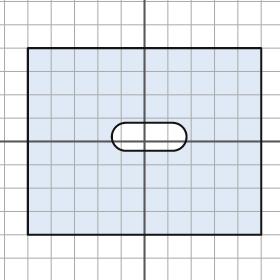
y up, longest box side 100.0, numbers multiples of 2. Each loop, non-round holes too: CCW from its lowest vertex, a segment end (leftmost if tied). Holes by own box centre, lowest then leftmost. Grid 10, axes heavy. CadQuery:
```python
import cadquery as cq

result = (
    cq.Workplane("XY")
    .moveTo(-50.0, -40.0)
    .lineTo(50.0, -40.0)
    .lineTo(50.0, 40.0)
    .lineTo(-50.0, 40.0)
    .close()
    .moveTo(-8.0, -4.0)
    .lineTo(12.0, -4.0)
    .threePointArc((18.0, 2.0), (12.0, 8.0))
    .lineTo(-8.0, 8.0)
    .threePointArc((-14.0, 2.0), (-8.0, -4.0))
    .close()
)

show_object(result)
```